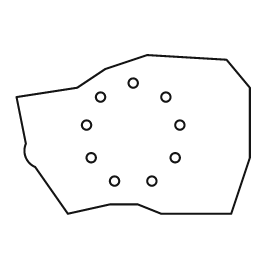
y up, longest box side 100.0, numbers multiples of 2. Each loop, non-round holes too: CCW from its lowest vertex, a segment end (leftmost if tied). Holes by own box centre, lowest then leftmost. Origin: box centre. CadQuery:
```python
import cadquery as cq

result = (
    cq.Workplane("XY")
    .moveTo(-28.0, -34.0)
    .lineTo(-10.0, -30.0)
    .lineTo(2.0, -30.0)
    .lineTo(12.0, -34.0)
    .lineTo(42.0, -34.0)
    .lineTo(50.0, -10.0)
    .lineTo(50.0, 20.0)
    .lineTo(40.0, 32.0)
    .lineTo(6.0, 34.0)
    .lineTo(-12.0, 28.0)
    .lineTo(-24.0, 20.0)
    .lineTo(-50.0, 16.0)
    .lineTo(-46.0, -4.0)
    .threePointArc((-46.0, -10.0), (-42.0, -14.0))
    .close()
    .moveTo(-8.0, -20.0)
    .circle(2.0)
    .moveTo(8.0, -20.0)
    .circle(2.0)
    .moveTo(-18.0, -10.0)
    .circle(2.0)
    .moveTo(18.0, -10.0)
    .circle(2.0)
    .moveTo(-20.0, 4.0)
    .circle(2.0)
    .moveTo(20.0, 4.0)
    .circle(2.0)
    .moveTo(-14.0, 16.0)
    .circle(2.0)
    .moveTo(14.0, 16.0)
    .circle(2.0)
    .moveTo(0.0, 22.0)
    .circle(2.0)
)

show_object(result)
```